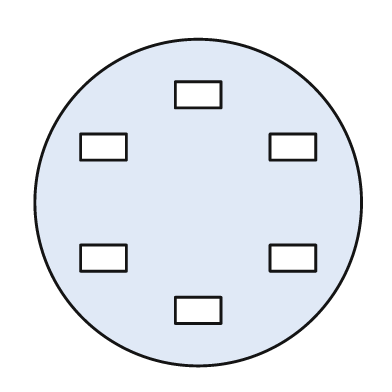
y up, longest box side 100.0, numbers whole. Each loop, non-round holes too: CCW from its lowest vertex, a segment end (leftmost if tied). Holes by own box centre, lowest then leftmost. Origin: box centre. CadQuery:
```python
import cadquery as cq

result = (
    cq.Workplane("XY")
    .moveTo(0.0, 0.0)
    .circle(50.0)
    .moveTo(-7.0, -37.0)
    .lineTo(7.0, -37.0)
    .lineTo(7.0, -29.0)
    .lineTo(-7.0, -29.0)
    .close()
    .moveTo(-36.0, -21.0)
    .lineTo(-22.0, -21.0)
    .lineTo(-22.0, -13.0)
    .lineTo(-36.0, -13.0)
    .close()
    .moveTo(22.0, -21.0)
    .lineTo(36.0, -21.0)
    .lineTo(36.0, -13.0)
    .lineTo(22.0, -13.0)
    .close()
    .moveTo(-36.0, 13.0)
    .lineTo(-22.0, 13.0)
    .lineTo(-22.0, 21.0)
    .lineTo(-36.0, 21.0)
    .close()
    .moveTo(22.0, 13.0)
    .lineTo(36.0, 13.0)
    .lineTo(36.0, 21.0)
    .lineTo(22.0, 21.0)
    .close()
    .moveTo(-7.0, 29.0)
    .lineTo(7.0, 29.0)
    .lineTo(7.0, 37.0)
    .lineTo(-7.0, 37.0)
    .close()
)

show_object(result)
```